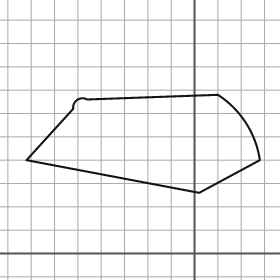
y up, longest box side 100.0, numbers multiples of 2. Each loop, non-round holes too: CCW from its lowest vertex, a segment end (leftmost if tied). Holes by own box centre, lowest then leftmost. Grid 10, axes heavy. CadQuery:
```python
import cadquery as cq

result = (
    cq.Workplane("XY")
    .moveTo(2.0, 26.0)
    .lineTo(28.0, 40.0)
    .threePointArc((22.0, 56.0), (10.0, 68.0))
    .lineTo(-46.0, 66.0)
    .threePointArc((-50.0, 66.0), (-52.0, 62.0))
    .lineTo(-72.0, 40.0)
    .close()
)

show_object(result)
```